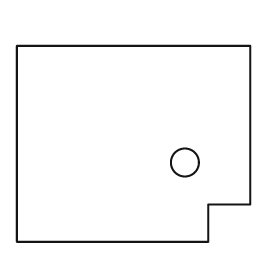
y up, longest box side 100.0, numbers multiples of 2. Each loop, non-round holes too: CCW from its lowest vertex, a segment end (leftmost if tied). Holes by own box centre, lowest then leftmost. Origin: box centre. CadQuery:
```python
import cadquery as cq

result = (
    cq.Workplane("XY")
    .moveTo(-50.0, -42.0)
    .lineTo(32.0, -42.0)
    .lineTo(32.0, -26.0)
    .lineTo(50.0, -26.0)
    .lineTo(50.0, 42.0)
    .lineTo(-50.0, 42.0)
    .close()
    .moveTo(22.0, -8.0)
    .circle(6.0)
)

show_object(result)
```